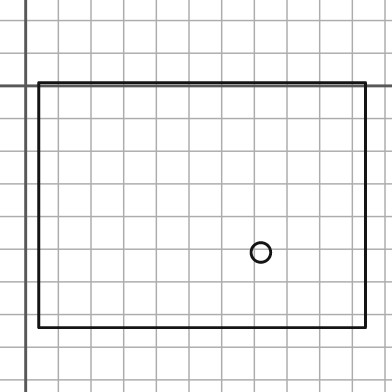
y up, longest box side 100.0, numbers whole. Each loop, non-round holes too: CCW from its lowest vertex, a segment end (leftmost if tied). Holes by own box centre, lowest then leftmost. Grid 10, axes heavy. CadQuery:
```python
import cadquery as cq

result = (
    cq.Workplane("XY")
    .moveTo(4.0, -74.0)
    .lineTo(104.0, -74.0)
    .lineTo(104.0, 1.0)
    .lineTo(4.0, 1.0)
    .close()
    .moveTo(72.0, -51.0)
    .circle(3.0)
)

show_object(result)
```